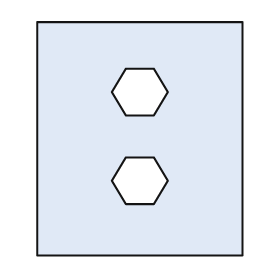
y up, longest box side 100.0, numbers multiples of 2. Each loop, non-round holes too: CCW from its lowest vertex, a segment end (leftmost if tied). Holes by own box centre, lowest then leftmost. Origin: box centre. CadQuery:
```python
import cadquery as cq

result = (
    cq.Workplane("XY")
    .moveTo(-44.0, -50.0)
    .lineTo(44.0, -50.0)
    .lineTo(44.0, 50.0)
    .lineTo(-44.0, 50.0)
    .close()
    .moveTo(-6.0, -28.0)
    .lineTo(6.0, -28.0)
    .lineTo(12.0, -18.0)
    .lineTo(6.0, -8.0)
    .lineTo(-6.0, -8.0)
    .lineTo(-12.0, -18.0)
    .close()
    .moveTo(-6.0, 10.0)
    .lineTo(6.0, 10.0)
    .lineTo(12.0, 20.0)
    .lineTo(6.0, 30.0)
    .lineTo(-6.0, 30.0)
    .lineTo(-12.0, 20.0)
    .close()
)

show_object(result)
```